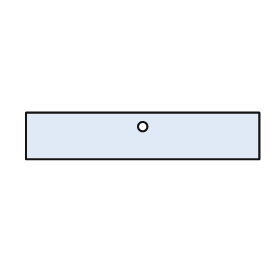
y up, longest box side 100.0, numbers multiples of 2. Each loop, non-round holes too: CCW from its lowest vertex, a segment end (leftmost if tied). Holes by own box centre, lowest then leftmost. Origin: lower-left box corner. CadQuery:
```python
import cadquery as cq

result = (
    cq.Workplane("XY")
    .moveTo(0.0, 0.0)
    .lineTo(100.0, 0.0)
    .lineTo(100.0, 20.0)
    .lineTo(0.0, 20.0)
    .close()
    .moveTo(50.0, 14.0)
    .circle(2.0)
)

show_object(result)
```